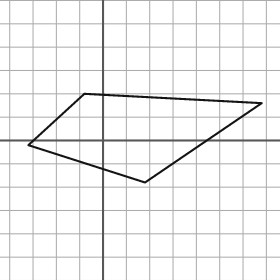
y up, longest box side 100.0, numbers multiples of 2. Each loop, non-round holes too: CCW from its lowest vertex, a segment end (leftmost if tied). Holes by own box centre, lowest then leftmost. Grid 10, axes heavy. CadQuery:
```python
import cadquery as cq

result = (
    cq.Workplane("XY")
    .moveTo(18.0, -18.0)
    .lineTo(68.0, 16.0)
    .lineTo(-8.0, 20.0)
    .lineTo(-32.0, -2.0)
    .close()
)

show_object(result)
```